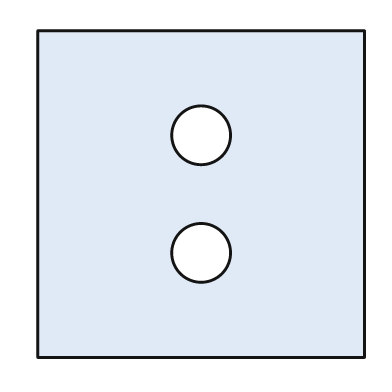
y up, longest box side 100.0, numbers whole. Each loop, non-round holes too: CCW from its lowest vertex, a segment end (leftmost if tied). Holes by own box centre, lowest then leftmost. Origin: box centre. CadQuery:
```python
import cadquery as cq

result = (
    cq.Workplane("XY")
    .moveTo(-50.0, -50.0)
    .lineTo(50.0, -50.0)
    .lineTo(50.0, 50.0)
    .lineTo(-50.0, 50.0)
    .close()
    .moveTo(0.0, -18.0)
    .circle(9.0)
    .moveTo(0.0, 18.0)
    .circle(9.0)
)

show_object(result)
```